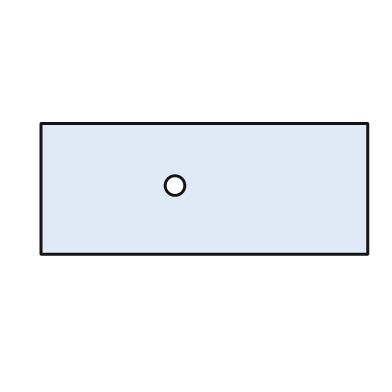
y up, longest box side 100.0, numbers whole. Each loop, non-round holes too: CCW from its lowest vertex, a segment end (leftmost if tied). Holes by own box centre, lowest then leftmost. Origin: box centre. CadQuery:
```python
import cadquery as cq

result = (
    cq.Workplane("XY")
    .moveTo(-50.0, -20.0)
    .lineTo(50.0, -20.0)
    .lineTo(50.0, 20.0)
    .lineTo(-50.0, 20.0)
    .close()
    .moveTo(-9.0, 1.0)
    .circle(3.0)
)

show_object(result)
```